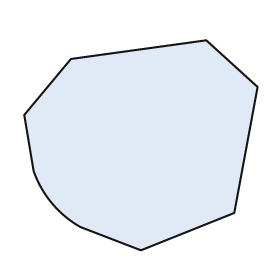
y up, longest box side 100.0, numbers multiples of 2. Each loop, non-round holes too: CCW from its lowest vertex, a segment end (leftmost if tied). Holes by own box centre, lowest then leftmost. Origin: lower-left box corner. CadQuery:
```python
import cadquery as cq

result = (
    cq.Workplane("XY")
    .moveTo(50.0, 0.0)
    .lineTo(90.0, 16.0)
    .lineTo(100.0, 70.0)
    .lineTo(78.0, 90.0)
    .lineTo(20.0, 82.0)
    .lineTo(0.0, 58.0)
    .lineTo(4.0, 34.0)
    .threePointArc((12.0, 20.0), (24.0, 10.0))
    .close()
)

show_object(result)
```